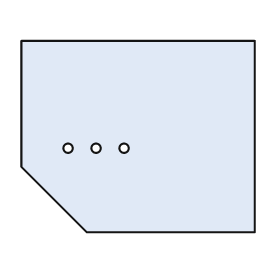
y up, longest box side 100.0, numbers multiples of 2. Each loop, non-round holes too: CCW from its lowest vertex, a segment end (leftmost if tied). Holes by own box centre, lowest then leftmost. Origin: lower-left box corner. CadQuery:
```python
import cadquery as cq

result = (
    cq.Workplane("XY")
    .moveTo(28.0, 0.0)
    .lineTo(100.0, 0.0)
    .lineTo(100.0, 82.0)
    .lineTo(0.0, 82.0)
    .lineTo(0.0, 28.0)
    .close()
    .moveTo(20.0, 36.0)
    .circle(2.0)
    .moveTo(32.0, 36.0)
    .circle(2.0)
    .moveTo(44.0, 36.0)
    .circle(2.0)
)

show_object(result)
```